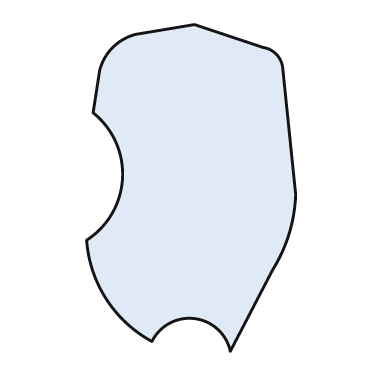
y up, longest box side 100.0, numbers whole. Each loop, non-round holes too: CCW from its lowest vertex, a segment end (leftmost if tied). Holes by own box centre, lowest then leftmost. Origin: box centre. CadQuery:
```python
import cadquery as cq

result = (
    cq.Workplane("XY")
    .moveTo(12.0, -50.0)
    .lineTo(25.0, -25.0)
    .threePointArc((30.0, -14.0), (32.0, -2.0))
    .lineTo(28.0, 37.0)
    .threePointArc((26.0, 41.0), (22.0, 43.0))
    .lineTo(1.0, 50.0)
    .lineTo(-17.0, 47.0)
    .threePointArc((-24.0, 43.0), (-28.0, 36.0))
    .lineTo(-30.0, 23.0)
    .threePointArc((-21.0, 3.0), (-32.0, -16.0))
    .threePointArc((-26.0, -34.0), (-12.0, -47.0))
    .threePointArc((1.0, -40.0), (12.0, -50.0))
    .close()
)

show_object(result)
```